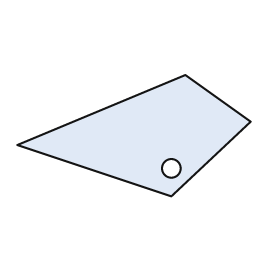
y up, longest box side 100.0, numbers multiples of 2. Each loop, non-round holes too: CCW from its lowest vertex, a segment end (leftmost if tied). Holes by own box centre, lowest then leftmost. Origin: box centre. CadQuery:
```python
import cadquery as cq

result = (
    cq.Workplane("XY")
    .moveTo(16.0, -26.0)
    .lineTo(50.0, 6.0)
    .lineTo(22.0, 26.0)
    .lineTo(-50.0, -4.0)
    .close()
    .moveTo(16.0, -14.0)
    .circle(4.0)
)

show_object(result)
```